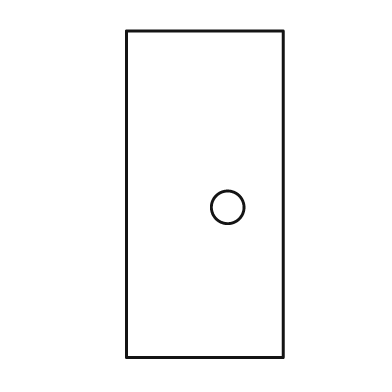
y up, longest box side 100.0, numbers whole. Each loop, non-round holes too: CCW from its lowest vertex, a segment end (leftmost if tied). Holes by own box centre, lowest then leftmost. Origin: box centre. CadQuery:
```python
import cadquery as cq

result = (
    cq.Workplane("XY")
    .moveTo(-24.0, -50.0)
    .lineTo(24.0, -50.0)
    .lineTo(24.0, 50.0)
    .lineTo(-24.0, 50.0)
    .close()
    .moveTo(7.0, -4.0)
    .circle(5.0)
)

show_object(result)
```